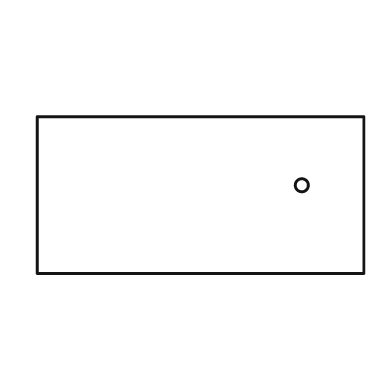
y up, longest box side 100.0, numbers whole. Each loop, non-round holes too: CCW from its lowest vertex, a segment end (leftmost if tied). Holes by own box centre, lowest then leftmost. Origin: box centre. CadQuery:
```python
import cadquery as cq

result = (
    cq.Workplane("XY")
    .moveTo(-50.0, -24.0)
    .lineTo(50.0, -24.0)
    .lineTo(50.0, 24.0)
    .lineTo(-50.0, 24.0)
    .close()
    .moveTo(31.0, 3.0)
    .circle(2.0)
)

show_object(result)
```